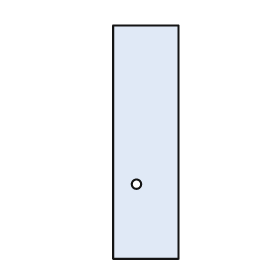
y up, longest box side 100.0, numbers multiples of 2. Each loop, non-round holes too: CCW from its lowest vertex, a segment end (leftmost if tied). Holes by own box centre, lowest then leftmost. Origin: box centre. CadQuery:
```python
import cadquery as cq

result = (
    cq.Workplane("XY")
    .moveTo(-14.0, -50.0)
    .lineTo(14.0, -50.0)
    .lineTo(14.0, 50.0)
    .lineTo(-14.0, 50.0)
    .close()
    .moveTo(-4.0, -18.0)
    .circle(2.0)
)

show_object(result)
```